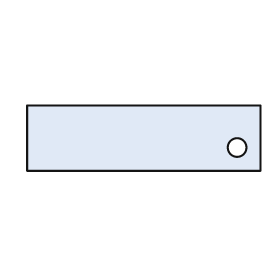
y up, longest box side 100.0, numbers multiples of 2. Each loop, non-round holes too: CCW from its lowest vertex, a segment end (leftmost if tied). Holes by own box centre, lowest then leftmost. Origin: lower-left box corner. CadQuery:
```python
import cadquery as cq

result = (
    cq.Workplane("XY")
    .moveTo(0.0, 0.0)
    .lineTo(100.0, 0.0)
    .lineTo(100.0, 28.0)
    .lineTo(0.0, 28.0)
    .close()
    .moveTo(90.0, 10.0)
    .circle(4.0)
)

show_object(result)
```